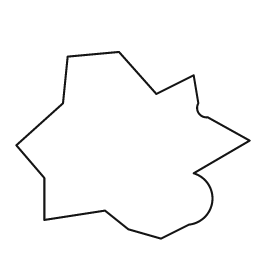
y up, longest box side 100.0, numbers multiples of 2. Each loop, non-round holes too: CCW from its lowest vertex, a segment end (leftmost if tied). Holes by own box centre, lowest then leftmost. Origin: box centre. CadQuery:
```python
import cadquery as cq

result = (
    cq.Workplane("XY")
    .moveTo(12.0, -40.0)
    .lineTo(24.0, -34.0)
    .threePointArc((34.0, -24.0), (26.0, -12.0))
    .lineTo(50.0, 2.0)
    .lineTo(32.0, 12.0)
    .threePointArc((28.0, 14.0), (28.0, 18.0))
    .lineTo(26.0, 30.0)
    .lineTo(10.0, 22.0)
    .lineTo(-6.0, 40.0)
    .lineTo(-28.0, 38.0)
    .lineTo(-30.0, 18.0)
    .lineTo(-50.0, 0.0)
    .lineTo(-38.0, -14.0)
    .lineTo(-38.0, -32.0)
    .lineTo(-12.0, -28.0)
    .lineTo(-2.0, -36.0)
    .close()
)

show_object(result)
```